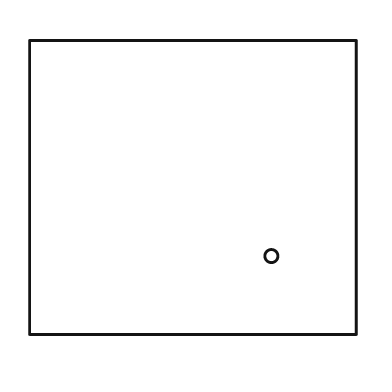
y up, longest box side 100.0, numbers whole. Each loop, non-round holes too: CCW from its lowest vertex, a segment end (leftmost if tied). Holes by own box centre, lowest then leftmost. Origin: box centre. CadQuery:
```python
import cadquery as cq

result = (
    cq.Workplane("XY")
    .moveTo(-50.0, -45.0)
    .lineTo(50.0, -45.0)
    .lineTo(50.0, 45.0)
    .lineTo(-50.0, 45.0)
    .close()
    .moveTo(24.0, -21.0)
    .circle(2.0)
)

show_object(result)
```